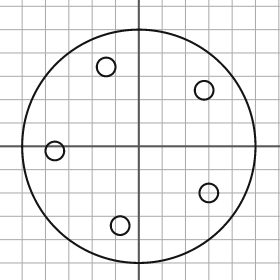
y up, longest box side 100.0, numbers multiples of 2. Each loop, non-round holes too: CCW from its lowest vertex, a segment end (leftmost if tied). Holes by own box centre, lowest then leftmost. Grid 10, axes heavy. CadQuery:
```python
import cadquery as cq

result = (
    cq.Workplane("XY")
    .moveTo(0.0, 0.0)
    .circle(50.0)
    .moveTo(-8.0, -34.0)
    .circle(4.0)
    .moveTo(30.0, -20.0)
    .circle(4.0)
    .moveTo(-36.0, -2.0)
    .circle(4.0)
    .moveTo(28.0, 24.0)
    .circle(4.0)
    .moveTo(-14.0, 34.0)
    .circle(4.0)
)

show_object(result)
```